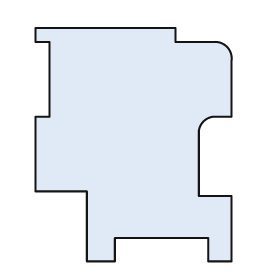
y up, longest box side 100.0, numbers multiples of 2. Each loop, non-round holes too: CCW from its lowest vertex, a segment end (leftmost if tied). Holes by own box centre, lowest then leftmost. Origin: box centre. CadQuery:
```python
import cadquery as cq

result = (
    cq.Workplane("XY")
    .moveTo(-20.0, -50.0)
    .lineTo(-8.0, -50.0)
    .lineTo(-8.0, -40.0)
    .lineTo(32.0, -40.0)
    .lineTo(32.0, -50.0)
    .lineTo(42.0, -50.0)
    .lineTo(42.0, -22.0)
    .lineTo(28.0, -22.0)
    .lineTo(28.0, 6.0)
    .threePointArc((30.0, 10.0), (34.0, 12.0))
    .lineTo(42.0, 12.0)
    .lineTo(42.0, 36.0)
    .threePointArc((40.0, 42.0), (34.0, 44.0))
    .lineTo(18.0, 44.0)
    .lineTo(18.0, 50.0)
    .lineTo(-42.0, 50.0)
    .lineTo(-42.0, 44.0)
    .lineTo(-36.0, 44.0)
    .lineTo(-36.0, 12.0)
    .lineTo(-42.0, 12.0)
    .lineTo(-42.0, -20.0)
    .lineTo(-20.0, -20.0)
    .close()
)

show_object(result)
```